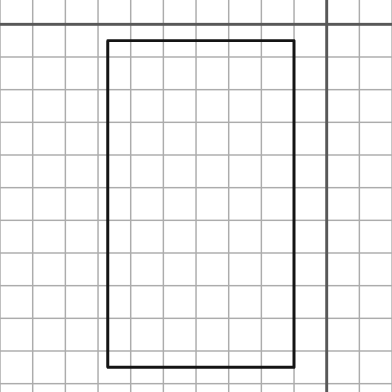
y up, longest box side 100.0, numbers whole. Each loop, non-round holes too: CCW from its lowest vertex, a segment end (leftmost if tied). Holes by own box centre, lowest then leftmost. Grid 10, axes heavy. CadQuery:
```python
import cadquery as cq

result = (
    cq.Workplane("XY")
    .moveTo(-67.0, -105.0)
    .lineTo(-10.0, -105.0)
    .lineTo(-10.0, -5.0)
    .lineTo(-67.0, -5.0)
    .close()
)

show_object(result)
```